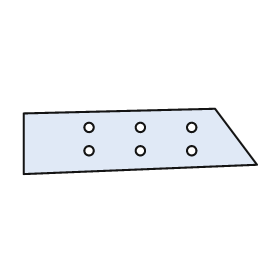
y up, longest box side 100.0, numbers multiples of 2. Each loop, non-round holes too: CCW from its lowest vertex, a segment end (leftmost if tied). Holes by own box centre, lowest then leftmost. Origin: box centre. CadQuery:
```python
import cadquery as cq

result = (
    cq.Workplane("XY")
    .moveTo(-50.0, -14.0)
    .lineTo(50.0, -10.0)
    .lineTo(32.0, 14.0)
    .lineTo(-50.0, 12.0)
    .close()
    .moveTo(-22.0, -4.0)
    .circle(2.0)
    .moveTo(0.0, -4.0)
    .circle(2.0)
    .moveTo(22.0, -4.0)
    .circle(2.0)
    .moveTo(-22.0, 6.0)
    .circle(2.0)
    .moveTo(0.0, 6.0)
    .circle(2.0)
    .moveTo(22.0, 6.0)
    .circle(2.0)
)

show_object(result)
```